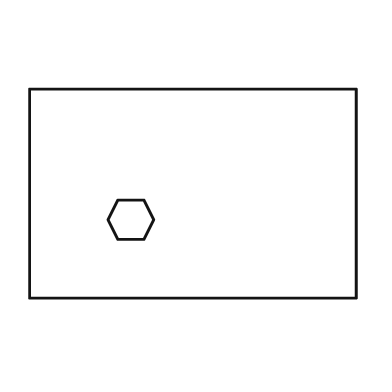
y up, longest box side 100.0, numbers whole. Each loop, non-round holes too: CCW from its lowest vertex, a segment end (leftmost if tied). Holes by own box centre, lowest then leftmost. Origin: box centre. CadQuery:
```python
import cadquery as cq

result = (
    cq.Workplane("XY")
    .moveTo(-50.0, -32.0)
    .lineTo(50.0, -32.0)
    .lineTo(50.0, 32.0)
    .lineTo(-50.0, 32.0)
    .close()
    .moveTo(-23.0, -14.0)
    .lineTo(-15.0, -14.0)
    .lineTo(-12.0, -8.0)
    .lineTo(-15.0, -2.0)
    .lineTo(-23.0, -2.0)
    .lineTo(-26.0, -8.0)
    .close()
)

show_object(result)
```